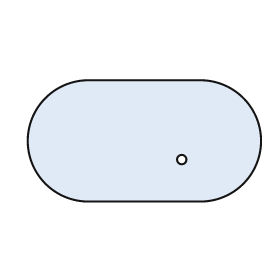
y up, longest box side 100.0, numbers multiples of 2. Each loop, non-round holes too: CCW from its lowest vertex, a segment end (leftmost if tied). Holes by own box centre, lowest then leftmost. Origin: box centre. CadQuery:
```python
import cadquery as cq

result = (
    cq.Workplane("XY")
    .moveTo(-24.0, -26.0)
    .lineTo(24.0, -26.0)
    .threePointArc((50.0, 0.0), (24.0, 26.0))
    .lineTo(-24.0, 26.0)
    .threePointArc((-50.0, 0.0), (-24.0, -26.0))
    .close()
    .moveTo(16.0, -8.0)
    .circle(2.0)
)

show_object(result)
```